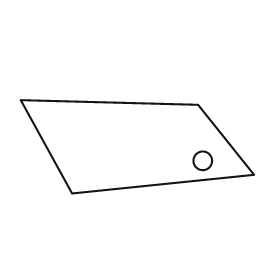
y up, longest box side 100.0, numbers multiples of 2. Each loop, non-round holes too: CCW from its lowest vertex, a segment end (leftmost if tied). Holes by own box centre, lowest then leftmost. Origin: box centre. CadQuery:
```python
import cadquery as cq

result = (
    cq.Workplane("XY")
    .moveTo(-28.0, -20.0)
    .lineTo(50.0, -12.0)
    .lineTo(26.0, 18.0)
    .lineTo(-50.0, 20.0)
    .close()
    .moveTo(28.0, -6.0)
    .circle(4.0)
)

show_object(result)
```